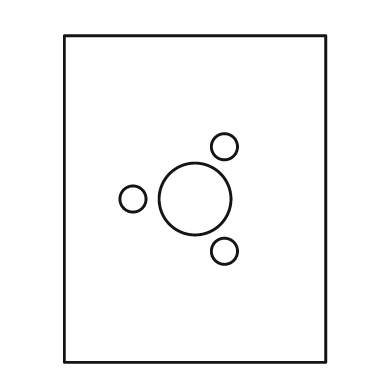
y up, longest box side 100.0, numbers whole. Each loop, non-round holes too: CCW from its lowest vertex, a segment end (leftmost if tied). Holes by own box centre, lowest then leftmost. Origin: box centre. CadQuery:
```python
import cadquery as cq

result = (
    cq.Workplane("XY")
    .moveTo(-40.0, -50.0)
    .lineTo(40.0, -50.0)
    .lineTo(40.0, 50.0)
    .lineTo(-40.0, 50.0)
    .close()
    .moveTo(9.0, -16.0)
    .circle(4.0)
    .moveTo(-19.0, 0.0)
    .circle(4.0)
    .moveTo(0.0, 0.0)
    .circle(11.0)
    .moveTo(9.0, 16.0)
    .circle(4.0)
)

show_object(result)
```